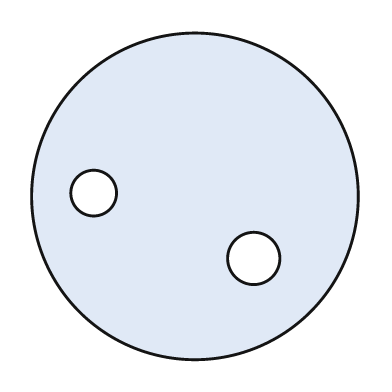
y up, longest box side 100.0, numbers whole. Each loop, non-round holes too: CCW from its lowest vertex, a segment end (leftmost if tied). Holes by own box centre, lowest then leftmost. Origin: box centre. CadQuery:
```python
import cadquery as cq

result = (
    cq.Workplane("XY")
    .moveTo(0.0, 0.0)
    .circle(50.0)
    .moveTo(18.0, -19.0)
    .circle(8.0)
    .moveTo(-31.0, 1.0)
    .circle(7.0)
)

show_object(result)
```